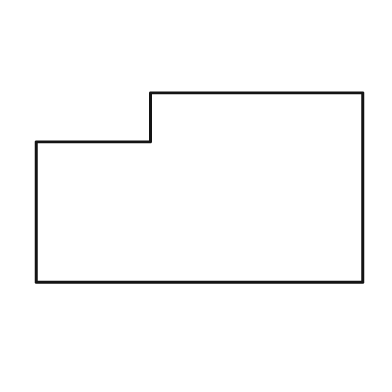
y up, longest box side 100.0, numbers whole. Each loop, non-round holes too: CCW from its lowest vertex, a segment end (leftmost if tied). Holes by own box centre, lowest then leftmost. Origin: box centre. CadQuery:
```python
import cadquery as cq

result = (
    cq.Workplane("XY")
    .moveTo(-50.0, -29.0)
    .lineTo(50.0, -29.0)
    .lineTo(50.0, 29.0)
    .lineTo(-15.0, 29.0)
    .lineTo(-15.0, 14.0)
    .lineTo(-50.0, 14.0)
    .close()
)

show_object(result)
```